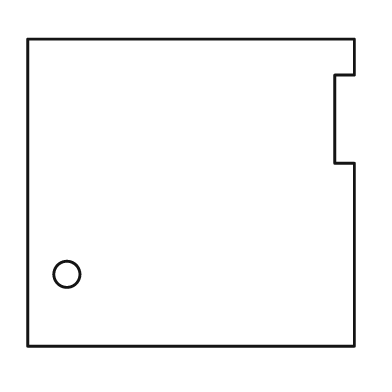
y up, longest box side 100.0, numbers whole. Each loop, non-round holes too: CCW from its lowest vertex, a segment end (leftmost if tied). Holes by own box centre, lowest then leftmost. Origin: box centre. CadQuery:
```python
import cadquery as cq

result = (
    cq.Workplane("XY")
    .moveTo(-50.0, -47.0)
    .lineTo(50.0, -47.0)
    .lineTo(50.0, 9.0)
    .lineTo(44.0, 9.0)
    .lineTo(44.0, 36.0)
    .lineTo(50.0, 36.0)
    .lineTo(50.0, 47.0)
    .lineTo(-50.0, 47.0)
    .close()
    .moveTo(-38.0, -25.0)
    .circle(4.0)
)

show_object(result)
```